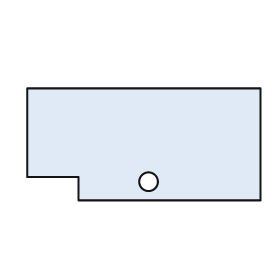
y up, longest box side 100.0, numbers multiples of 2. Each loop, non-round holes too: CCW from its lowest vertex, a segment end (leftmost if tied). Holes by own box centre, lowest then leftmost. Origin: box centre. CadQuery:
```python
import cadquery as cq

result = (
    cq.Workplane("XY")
    .moveTo(-28.0, -24.0)
    .lineTo(50.0, -24.0)
    .lineTo(50.0, 24.0)
    .lineTo(-50.0, 24.0)
    .lineTo(-50.0, -14.0)
    .lineTo(-28.0, -14.0)
    .close()
    .moveTo(2.0, -16.0)
    .circle(4.0)
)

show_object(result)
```